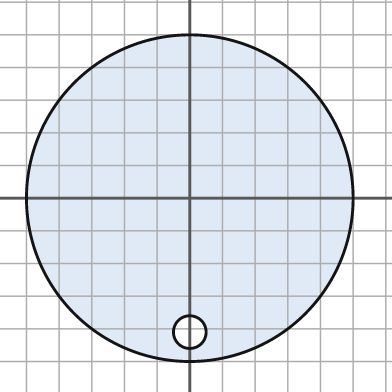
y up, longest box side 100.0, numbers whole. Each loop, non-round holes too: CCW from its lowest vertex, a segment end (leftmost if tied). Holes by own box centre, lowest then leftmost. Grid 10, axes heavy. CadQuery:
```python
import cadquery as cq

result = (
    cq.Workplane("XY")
    .moveTo(0.0, 0.0)
    .circle(50.0)
    .moveTo(0.0, -41.0)
    .circle(5.0)
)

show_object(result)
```